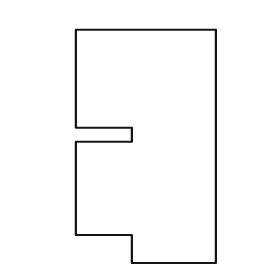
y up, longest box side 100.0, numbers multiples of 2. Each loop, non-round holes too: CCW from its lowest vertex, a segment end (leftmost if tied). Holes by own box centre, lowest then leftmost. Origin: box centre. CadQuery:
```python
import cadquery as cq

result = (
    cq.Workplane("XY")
    .moveTo(-6.0, -50.0)
    .lineTo(30.0, -50.0)
    .lineTo(30.0, 50.0)
    .lineTo(-30.0, 50.0)
    .lineTo(-30.0, 8.0)
    .lineTo(-6.0, 8.0)
    .lineTo(-6.0, 2.0)
    .lineTo(-30.0, 2.0)
    .lineTo(-30.0, -38.0)
    .lineTo(-6.0, -38.0)
    .close()
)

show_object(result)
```